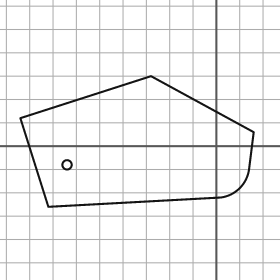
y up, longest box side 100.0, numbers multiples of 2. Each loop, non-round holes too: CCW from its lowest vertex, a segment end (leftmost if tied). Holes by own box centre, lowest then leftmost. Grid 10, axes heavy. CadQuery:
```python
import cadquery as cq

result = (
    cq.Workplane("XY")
    .moveTo(-72.0, -26.0)
    .lineTo(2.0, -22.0)
    .threePointArc((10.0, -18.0), (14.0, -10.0))
    .lineTo(16.0, 6.0)
    .lineTo(-28.0, 30.0)
    .lineTo(-84.0, 12.0)
    .close()
    .moveTo(-64.0, -8.0)
    .circle(2.0)
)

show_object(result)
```